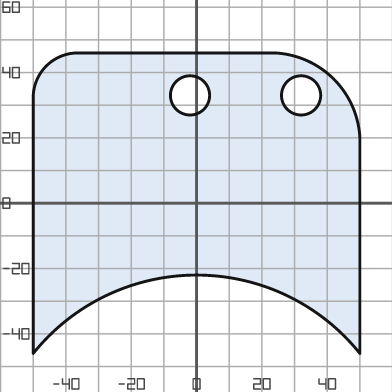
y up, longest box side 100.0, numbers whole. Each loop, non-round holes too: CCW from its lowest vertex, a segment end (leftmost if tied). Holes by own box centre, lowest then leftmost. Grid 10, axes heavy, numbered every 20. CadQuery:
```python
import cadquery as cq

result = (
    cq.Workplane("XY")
    .moveTo(-50.0, -46.0)
    .threePointArc((0.0, -22.0), (50.0, -46.0))
    .lineTo(50.0, 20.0)
    .threePointArc((42.0, 38.0), (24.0, 46.0))
    .lineTo(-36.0, 46.0)
    .threePointArc((-46.0, 42.0), (-50.0, 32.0))
    .close()
    .moveTo(-2.0, 33.0)
    .circle(6.0)
    .moveTo(32.0, 33.0)
    .circle(6.0)
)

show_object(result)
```